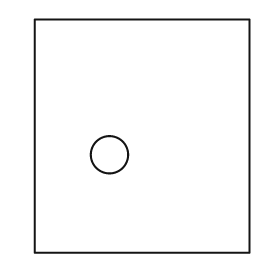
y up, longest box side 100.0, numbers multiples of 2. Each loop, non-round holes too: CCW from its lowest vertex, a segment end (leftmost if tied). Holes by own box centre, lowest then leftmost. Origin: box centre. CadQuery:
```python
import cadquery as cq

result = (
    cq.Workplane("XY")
    .moveTo(-46.0, -50.0)
    .lineTo(46.0, -50.0)
    .lineTo(46.0, 50.0)
    .lineTo(-46.0, 50.0)
    .close()
    .moveTo(-14.0, -8.0)
    .circle(8.0)
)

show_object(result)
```